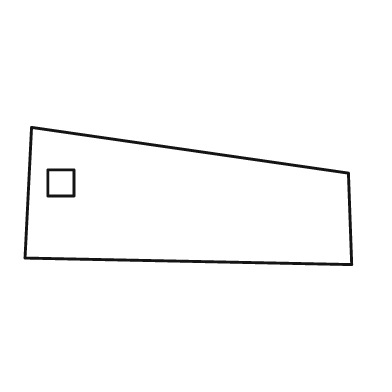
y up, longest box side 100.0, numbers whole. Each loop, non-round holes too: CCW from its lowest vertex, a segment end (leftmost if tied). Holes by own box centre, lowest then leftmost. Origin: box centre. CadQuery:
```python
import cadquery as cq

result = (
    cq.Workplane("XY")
    .moveTo(50.0, -21.0)
    .lineTo(49.0, 7.0)
    .lineTo(-48.0, 21.0)
    .lineTo(-50.0, -19.0)
    .close()
    .moveTo(-43.0, 0.0)
    .lineTo(-35.0, 0.0)
    .lineTo(-35.0, 8.0)
    .lineTo(-43.0, 8.0)
    .close()
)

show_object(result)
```